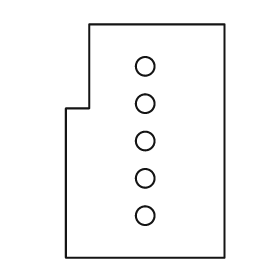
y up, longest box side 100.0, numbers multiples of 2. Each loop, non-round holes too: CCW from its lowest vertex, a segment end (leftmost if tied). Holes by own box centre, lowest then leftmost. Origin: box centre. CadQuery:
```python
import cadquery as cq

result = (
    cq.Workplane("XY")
    .moveTo(-34.0, -50.0)
    .lineTo(34.0, -50.0)
    .lineTo(34.0, 50.0)
    .lineTo(-24.0, 50.0)
    .lineTo(-24.0, 14.0)
    .lineTo(-34.0, 14.0)
    .close()
    .moveTo(0.0, -32.0)
    .circle(4.0)
    .moveTo(0.0, -16.0)
    .circle(4.0)
    .moveTo(0.0, 0.0)
    .circle(4.0)
    .moveTo(0.0, 16.0)
    .circle(4.0)
    .moveTo(0.0, 32.0)
    .circle(4.0)
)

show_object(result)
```